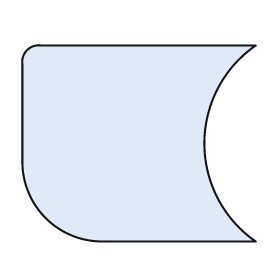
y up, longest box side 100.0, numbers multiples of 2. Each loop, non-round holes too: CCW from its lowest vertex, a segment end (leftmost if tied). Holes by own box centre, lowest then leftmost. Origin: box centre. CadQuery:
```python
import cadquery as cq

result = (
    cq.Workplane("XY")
    .moveTo(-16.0, -42.0)
    .lineTo(50.0, -42.0)
    .threePointArc((28.0, 0.0), (50.0, 42.0))
    .lineTo(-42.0, 42.0)
    .threePointArc((-48.0, 40.0), (-50.0, 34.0))
    .lineTo(-50.0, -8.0)
    .threePointArc((-40.0, -32.0), (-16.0, -42.0))
    .close()
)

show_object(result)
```